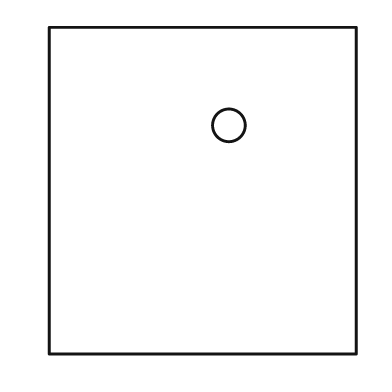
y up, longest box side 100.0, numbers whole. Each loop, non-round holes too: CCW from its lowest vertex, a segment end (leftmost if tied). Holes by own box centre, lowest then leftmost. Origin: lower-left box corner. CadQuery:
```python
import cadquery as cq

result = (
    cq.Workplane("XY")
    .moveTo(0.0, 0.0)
    .lineTo(94.0, 0.0)
    .lineTo(94.0, 100.0)
    .lineTo(0.0, 100.0)
    .close()
    .moveTo(55.0, 70.0)
    .circle(5.0)
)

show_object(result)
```